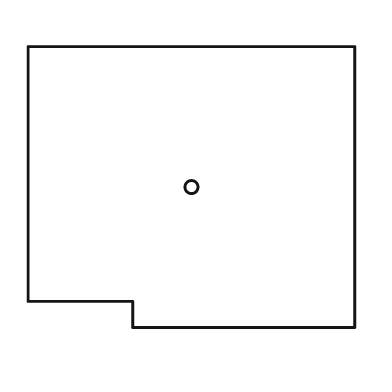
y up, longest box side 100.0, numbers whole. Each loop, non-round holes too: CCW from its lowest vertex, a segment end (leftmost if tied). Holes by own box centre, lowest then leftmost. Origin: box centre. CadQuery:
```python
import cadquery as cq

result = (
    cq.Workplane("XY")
    .moveTo(-18.0, -43.0)
    .lineTo(50.0, -43.0)
    .lineTo(50.0, 43.0)
    .lineTo(-50.0, 43.0)
    .lineTo(-50.0, -35.0)
    .lineTo(-18.0, -35.0)
    .close()
    .moveTo(0.0, 0.0)
    .circle(2.0)
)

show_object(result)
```